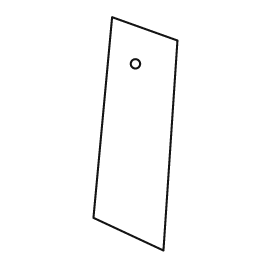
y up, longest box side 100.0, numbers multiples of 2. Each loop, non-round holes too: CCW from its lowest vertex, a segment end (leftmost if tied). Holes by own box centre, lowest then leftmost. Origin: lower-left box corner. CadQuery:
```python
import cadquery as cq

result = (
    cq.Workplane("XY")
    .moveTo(30.0, 0.0)
    .lineTo(36.0, 90.0)
    .lineTo(8.0, 100.0)
    .lineTo(0.0, 14.0)
    .close()
    .moveTo(18.0, 80.0)
    .circle(2.0)
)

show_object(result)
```